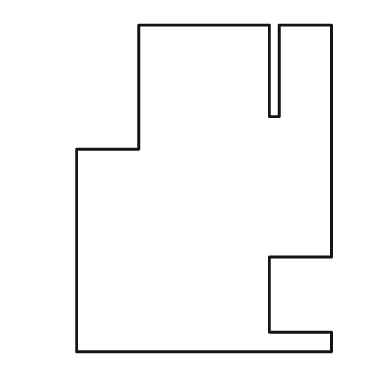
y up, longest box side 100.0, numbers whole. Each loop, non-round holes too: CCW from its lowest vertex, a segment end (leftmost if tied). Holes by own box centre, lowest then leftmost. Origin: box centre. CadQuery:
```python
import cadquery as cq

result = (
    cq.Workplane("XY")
    .moveTo(-39.0, -50.0)
    .lineTo(39.0, -50.0)
    .lineTo(39.0, -44.0)
    .lineTo(20.0, -44.0)
    .lineTo(20.0, -21.0)
    .lineTo(39.0, -21.0)
    .lineTo(39.0, 50.0)
    .lineTo(23.0, 50.0)
    .lineTo(23.0, 22.0)
    .lineTo(20.0, 22.0)
    .lineTo(20.0, 50.0)
    .lineTo(-20.0, 50.0)
    .lineTo(-20.0, 12.0)
    .lineTo(-39.0, 12.0)
    .close()
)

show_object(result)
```